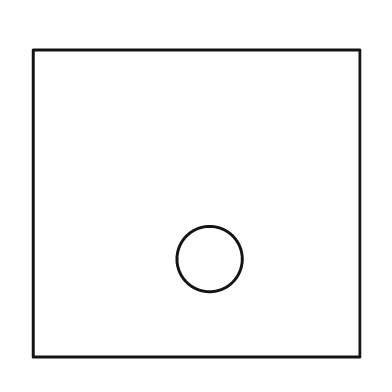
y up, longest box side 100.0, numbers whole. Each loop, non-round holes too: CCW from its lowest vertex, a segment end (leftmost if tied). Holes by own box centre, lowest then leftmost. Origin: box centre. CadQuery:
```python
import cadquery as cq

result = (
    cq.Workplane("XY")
    .moveTo(-50.0, -47.0)
    .lineTo(50.0, -47.0)
    .lineTo(50.0, 47.0)
    .lineTo(-50.0, 47.0)
    .close()
    .moveTo(4.0, -17.0)
    .circle(10.0)
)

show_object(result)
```